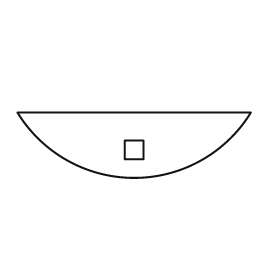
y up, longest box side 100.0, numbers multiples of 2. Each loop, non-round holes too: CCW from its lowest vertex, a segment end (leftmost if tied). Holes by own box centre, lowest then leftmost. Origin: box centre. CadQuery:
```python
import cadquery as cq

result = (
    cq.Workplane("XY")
    .moveTo(-50.0, 14.0)
    .threePointArc((0.0, -14.0), (50.0, 14.0))
    .close()
    .moveTo(-4.0, -6.0)
    .lineTo(4.0, -6.0)
    .lineTo(4.0, 2.0)
    .lineTo(-4.0, 2.0)
    .close()
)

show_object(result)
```